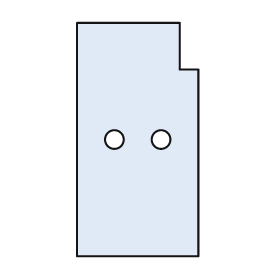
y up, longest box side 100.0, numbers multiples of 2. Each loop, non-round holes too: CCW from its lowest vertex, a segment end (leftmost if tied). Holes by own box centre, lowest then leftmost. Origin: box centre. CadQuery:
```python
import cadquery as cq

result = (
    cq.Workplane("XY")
    .moveTo(-26.0, -50.0)
    .lineTo(26.0, -50.0)
    .lineTo(26.0, 30.0)
    .lineTo(18.0, 30.0)
    .lineTo(18.0, 50.0)
    .lineTo(-26.0, 50.0)
    .close()
    .moveTo(-10.0, 0.0)
    .circle(4.0)
    .moveTo(10.0, 0.0)
    .circle(4.0)
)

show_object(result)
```